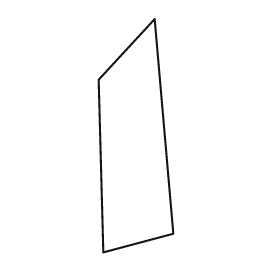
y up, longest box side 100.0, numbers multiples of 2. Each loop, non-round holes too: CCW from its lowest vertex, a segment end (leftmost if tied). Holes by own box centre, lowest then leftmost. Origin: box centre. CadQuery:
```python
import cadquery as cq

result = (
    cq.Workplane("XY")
    .moveTo(-14.0, -50.0)
    .lineTo(16.0, -42.0)
    .lineTo(8.0, 50.0)
    .lineTo(-16.0, 24.0)
    .close()
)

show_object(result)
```